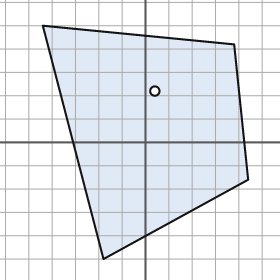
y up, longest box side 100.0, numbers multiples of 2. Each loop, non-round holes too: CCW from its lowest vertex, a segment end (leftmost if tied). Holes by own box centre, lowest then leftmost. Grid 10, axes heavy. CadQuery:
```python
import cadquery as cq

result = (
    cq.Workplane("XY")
    .moveTo(-18.0, -50.0)
    .lineTo(44.0, -16.0)
    .lineTo(38.0, 42.0)
    .lineTo(-44.0, 50.0)
    .close()
    .moveTo(4.0, 22.0)
    .circle(2.0)
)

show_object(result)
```